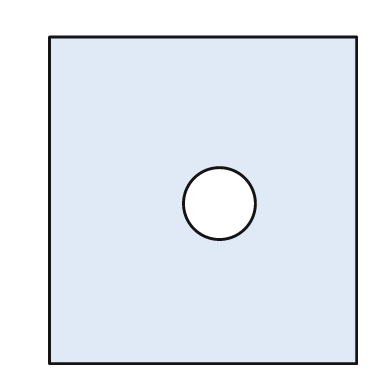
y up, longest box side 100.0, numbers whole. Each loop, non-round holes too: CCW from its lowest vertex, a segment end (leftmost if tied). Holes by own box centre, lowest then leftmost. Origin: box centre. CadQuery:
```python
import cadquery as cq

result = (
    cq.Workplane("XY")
    .moveTo(-47.0, -50.0)
    .lineTo(47.0, -50.0)
    .lineTo(47.0, 50.0)
    .lineTo(-47.0, 50.0)
    .close()
    .moveTo(5.0, -1.0)
    .circle(11.0)
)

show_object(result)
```